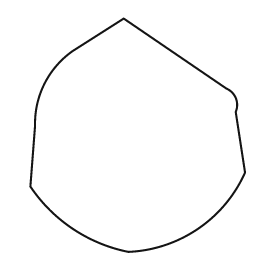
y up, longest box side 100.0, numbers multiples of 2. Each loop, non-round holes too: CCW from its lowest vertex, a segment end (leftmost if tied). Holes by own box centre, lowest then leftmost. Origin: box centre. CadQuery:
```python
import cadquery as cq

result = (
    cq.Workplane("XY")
    .moveTo(-4.0, -50.0)
    .threePointArc((26.0, -40.0), (46.0, -16.0))
    .lineTo(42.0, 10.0)
    .threePointArc((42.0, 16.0), (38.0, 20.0))
    .lineTo(-6.0, 50.0)
    .lineTo(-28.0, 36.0)
    .threePointArc((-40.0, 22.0), (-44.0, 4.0))
    .lineTo(-46.0, -22.0)
    .threePointArc((-28.0, -40.0), (-4.0, -50.0))
    .close()
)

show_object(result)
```